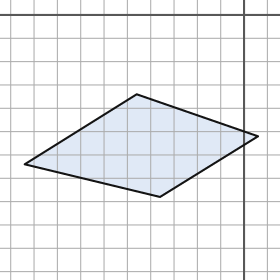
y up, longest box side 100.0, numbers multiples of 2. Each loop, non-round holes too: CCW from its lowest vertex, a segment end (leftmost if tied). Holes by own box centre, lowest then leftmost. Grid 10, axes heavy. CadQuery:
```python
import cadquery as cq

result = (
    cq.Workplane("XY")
    .moveTo(-36.0, -78.0)
    .lineTo(6.0, -52.0)
    .lineTo(-46.0, -34.0)
    .lineTo(-94.0, -64.0)
    .close()
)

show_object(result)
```